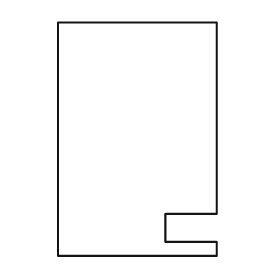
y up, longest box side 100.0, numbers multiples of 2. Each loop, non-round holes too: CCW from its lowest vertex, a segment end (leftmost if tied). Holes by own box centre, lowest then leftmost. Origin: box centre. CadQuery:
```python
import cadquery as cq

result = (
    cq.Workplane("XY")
    .moveTo(-34.0, -50.0)
    .lineTo(34.0, -50.0)
    .lineTo(34.0, -44.0)
    .lineTo(12.0, -44.0)
    .lineTo(12.0, -32.0)
    .lineTo(34.0, -32.0)
    .lineTo(34.0, 50.0)
    .lineTo(-34.0, 50.0)
    .close()
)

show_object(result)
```